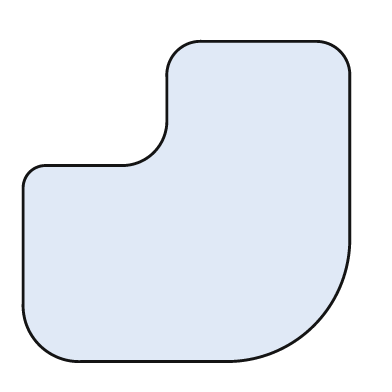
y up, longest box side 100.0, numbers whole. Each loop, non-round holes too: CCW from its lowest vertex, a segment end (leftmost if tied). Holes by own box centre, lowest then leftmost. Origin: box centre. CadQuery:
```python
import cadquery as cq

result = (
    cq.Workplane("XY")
    .moveTo(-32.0, -49.0)
    .lineTo(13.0, -49.0)
    .threePointArc((39.0, -38.0), (50.0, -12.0))
    .lineTo(50.0, 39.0)
    .threePointArc((47.0, 46.0), (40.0, 49.0))
    .lineTo(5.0, 49.0)
    .threePointArc((-3.0, 46.0), (-6.0, 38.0))
    .lineTo(-6.0, 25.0)
    .threePointArc((-10.0, 15.0), (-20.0, 11.0))
    .lineTo(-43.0, 11.0)
    .threePointArc((-48.0, 9.0), (-50.0, 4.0))
    .lineTo(-50.0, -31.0)
    .threePointArc((-45.0, -44.0), (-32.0, -49.0))
    .close()
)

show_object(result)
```